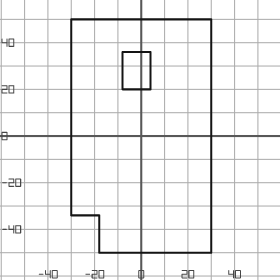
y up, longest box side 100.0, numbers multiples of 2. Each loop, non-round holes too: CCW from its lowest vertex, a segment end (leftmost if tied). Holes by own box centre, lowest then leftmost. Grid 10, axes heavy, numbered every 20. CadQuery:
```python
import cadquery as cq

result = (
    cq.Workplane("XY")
    .moveTo(-18.0, -50.0)
    .lineTo(30.0, -50.0)
    .lineTo(30.0, 50.0)
    .lineTo(-30.0, 50.0)
    .lineTo(-30.0, -34.0)
    .lineTo(-18.0, -34.0)
    .close()
    .moveTo(-8.0, 20.0)
    .lineTo(4.0, 20.0)
    .lineTo(4.0, 36.0)
    .lineTo(-8.0, 36.0)
    .close()
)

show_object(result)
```